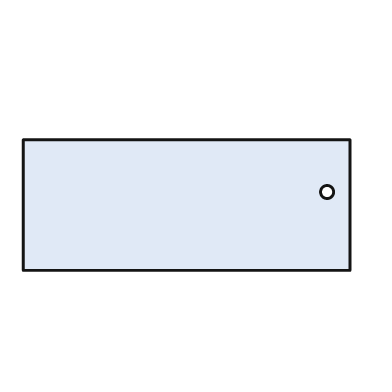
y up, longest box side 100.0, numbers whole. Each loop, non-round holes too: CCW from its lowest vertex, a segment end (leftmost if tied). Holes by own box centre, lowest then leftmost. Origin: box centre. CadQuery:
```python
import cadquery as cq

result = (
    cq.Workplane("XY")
    .moveTo(-50.0, -20.0)
    .lineTo(50.0, -20.0)
    .lineTo(50.0, 20.0)
    .lineTo(-50.0, 20.0)
    .close()
    .moveTo(43.0, 4.0)
    .circle(2.0)
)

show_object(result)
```